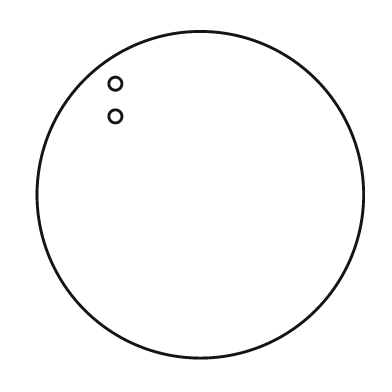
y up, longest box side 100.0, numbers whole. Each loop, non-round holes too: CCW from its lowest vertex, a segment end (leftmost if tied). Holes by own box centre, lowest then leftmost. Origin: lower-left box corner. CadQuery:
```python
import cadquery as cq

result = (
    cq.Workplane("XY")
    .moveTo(50.0, 50.0)
    .circle(50.0)
    .moveTo(24.0, 74.0)
    .circle(2.0)
    .moveTo(24.0, 84.0)
    .circle(2.0)
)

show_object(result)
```